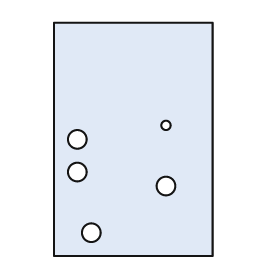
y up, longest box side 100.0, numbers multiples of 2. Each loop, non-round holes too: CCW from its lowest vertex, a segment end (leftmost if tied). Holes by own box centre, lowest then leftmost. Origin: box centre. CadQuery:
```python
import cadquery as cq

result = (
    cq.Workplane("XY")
    .moveTo(-34.0, -50.0)
    .lineTo(34.0, -50.0)
    .lineTo(34.0, 50.0)
    .lineTo(-34.0, 50.0)
    .close()
    .moveTo(-18.0, -40.0)
    .circle(4.0)
    .moveTo(14.0, -20.0)
    .circle(4.0)
    .moveTo(-24.0, -14.0)
    .circle(4.0)
    .moveTo(-24.0, 0.0)
    .circle(4.0)
    .moveTo(14.0, 6.0)
    .circle(2.0)
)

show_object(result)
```